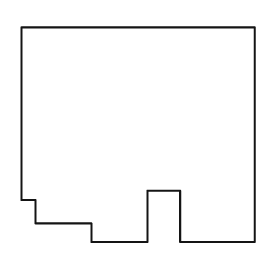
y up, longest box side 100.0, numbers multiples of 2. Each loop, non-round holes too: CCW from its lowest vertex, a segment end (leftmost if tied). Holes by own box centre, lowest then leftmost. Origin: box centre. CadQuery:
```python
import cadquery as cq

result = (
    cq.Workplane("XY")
    .moveTo(-20.0, -46.0)
    .lineTo(4.0, -46.0)
    .lineTo(4.0, -24.0)
    .lineTo(18.0, -24.0)
    .lineTo(18.0, -46.0)
    .lineTo(50.0, -46.0)
    .lineTo(50.0, 46.0)
    .lineTo(-50.0, 46.0)
    .lineTo(-50.0, -28.0)
    .lineTo(-44.0, -28.0)
    .lineTo(-44.0, -38.0)
    .lineTo(-20.0, -38.0)
    .close()
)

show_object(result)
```